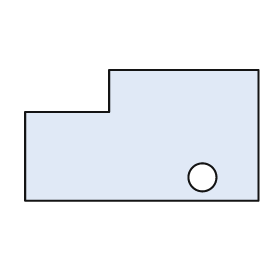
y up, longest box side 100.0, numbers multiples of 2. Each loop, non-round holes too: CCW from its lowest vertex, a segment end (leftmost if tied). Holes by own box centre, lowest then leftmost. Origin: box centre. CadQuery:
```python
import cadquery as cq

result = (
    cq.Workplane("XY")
    .moveTo(-50.0, -28.0)
    .lineTo(50.0, -28.0)
    .lineTo(50.0, 28.0)
    .lineTo(-14.0, 28.0)
    .lineTo(-14.0, 10.0)
    .lineTo(-50.0, 10.0)
    .close()
    .moveTo(26.0, -18.0)
    .circle(6.0)
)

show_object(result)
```